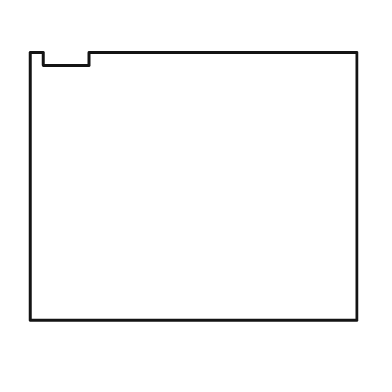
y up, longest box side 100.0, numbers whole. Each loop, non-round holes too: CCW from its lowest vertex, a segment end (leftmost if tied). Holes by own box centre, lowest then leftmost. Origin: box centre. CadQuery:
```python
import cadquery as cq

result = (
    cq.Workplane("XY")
    .moveTo(-50.0, -41.0)
    .lineTo(50.0, -41.0)
    .lineTo(50.0, 41.0)
    .lineTo(-32.0, 41.0)
    .lineTo(-32.0, 37.0)
    .lineTo(-46.0, 37.0)
    .lineTo(-46.0, 41.0)
    .lineTo(-50.0, 41.0)
    .close()
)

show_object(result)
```